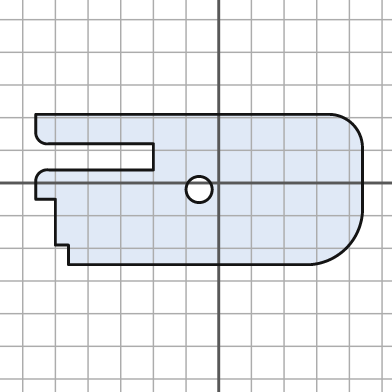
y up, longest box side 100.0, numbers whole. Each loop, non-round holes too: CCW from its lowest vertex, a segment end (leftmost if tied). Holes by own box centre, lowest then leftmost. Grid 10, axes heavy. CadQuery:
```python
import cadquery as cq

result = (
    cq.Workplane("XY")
    .moveTo(-46.0, -25.0)
    .lineTo(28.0, -25.0)
    .threePointArc((39.0, -20.0), (44.0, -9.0))
    .lineTo(44.0, 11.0)
    .threePointArc((41.0, 18.0), (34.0, 21.0))
    .lineTo(-56.0, 21.0)
    .lineTo(-56.0, 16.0)
    .threePointArc((-55.0, 13.0), (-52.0, 12.0))
    .lineTo(-20.0, 12.0)
    .lineTo(-20.0, 4.0)
    .lineTo(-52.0, 4.0)
    .threePointArc((-55.0, 3.0), (-56.0, 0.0))
    .lineTo(-56.0, -5.0)
    .lineTo(-50.0, -5.0)
    .lineTo(-50.0, -19.0)
    .lineTo(-46.0, -19.0)
    .close()
    .moveTo(-6.0, -2.0)
    .circle(4.0)
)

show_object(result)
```